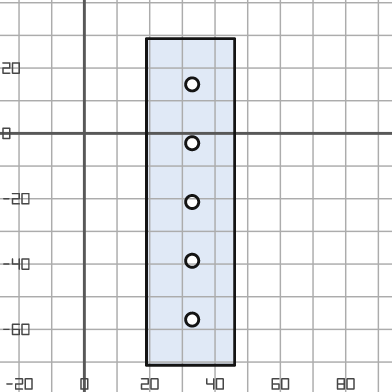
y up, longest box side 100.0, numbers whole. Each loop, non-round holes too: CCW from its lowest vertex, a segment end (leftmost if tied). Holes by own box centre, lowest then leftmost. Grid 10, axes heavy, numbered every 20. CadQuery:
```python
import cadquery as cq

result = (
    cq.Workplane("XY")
    .moveTo(19.0, -71.0)
    .lineTo(46.0, -71.0)
    .lineTo(46.0, 29.0)
    .lineTo(19.0, 29.0)
    .close()
    .moveTo(33.0, -57.0)
    .circle(2.0)
    .moveTo(33.0, -39.0)
    .circle(2.0)
    .moveTo(33.0, -21.0)
    .circle(2.0)
    .moveTo(33.0, -3.0)
    .circle(2.0)
    .moveTo(33.0, 15.0)
    .circle(2.0)
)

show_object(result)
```